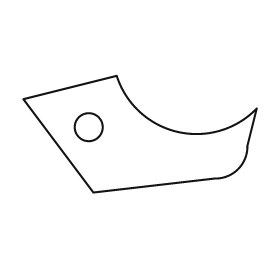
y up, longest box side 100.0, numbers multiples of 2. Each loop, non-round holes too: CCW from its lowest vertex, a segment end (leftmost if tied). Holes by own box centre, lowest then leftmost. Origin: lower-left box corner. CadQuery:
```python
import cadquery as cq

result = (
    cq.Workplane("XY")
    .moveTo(30.0, 0.0)
    .lineTo(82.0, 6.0)
    .threePointArc((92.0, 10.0), (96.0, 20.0))
    .lineTo(100.0, 36.0)
    .threePointArc((66.0, 26.0), (40.0, 50.0))
    .lineTo(0.0, 40.0)
    .close()
    .moveTo(28.0, 28.0)
    .circle(6.0)
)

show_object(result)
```